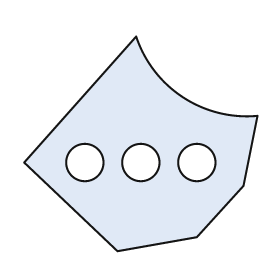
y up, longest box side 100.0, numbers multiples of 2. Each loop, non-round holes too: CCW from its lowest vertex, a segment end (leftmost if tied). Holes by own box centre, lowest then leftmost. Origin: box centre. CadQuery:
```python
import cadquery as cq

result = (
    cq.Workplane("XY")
    .moveTo(-10.0, -46.0)
    .lineTo(24.0, -40.0)
    .lineTo(44.0, -18.0)
    .lineTo(50.0, 12.0)
    .threePointArc((18.0, 20.0), (-2.0, 46.0))
    .lineTo(-50.0, -8.0)
    .close()
    .moveTo(-24.0, -8.0)
    .circle(8.0)
    .moveTo(0.0, -8.0)
    .circle(8.0)
    .moveTo(24.0, -8.0)
    .circle(8.0)
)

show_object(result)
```